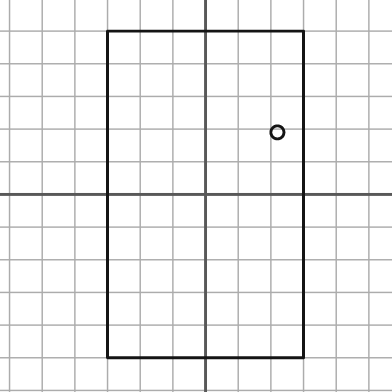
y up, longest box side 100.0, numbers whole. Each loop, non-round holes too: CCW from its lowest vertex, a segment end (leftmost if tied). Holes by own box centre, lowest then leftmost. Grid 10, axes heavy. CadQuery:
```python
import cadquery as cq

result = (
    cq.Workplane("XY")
    .moveTo(-30.0, -50.0)
    .lineTo(30.0, -50.0)
    .lineTo(30.0, 50.0)
    .lineTo(-30.0, 50.0)
    .close()
    .moveTo(22.0, 19.0)
    .circle(2.0)
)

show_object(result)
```